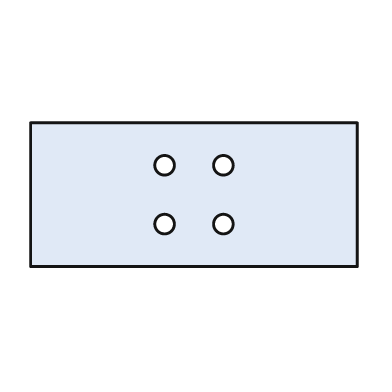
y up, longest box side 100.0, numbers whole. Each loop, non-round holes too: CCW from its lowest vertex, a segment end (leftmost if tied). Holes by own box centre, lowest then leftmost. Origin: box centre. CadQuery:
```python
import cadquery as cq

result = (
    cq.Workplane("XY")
    .moveTo(-50.0, -22.0)
    .lineTo(50.0, -22.0)
    .lineTo(50.0, 22.0)
    .lineTo(-50.0, 22.0)
    .close()
    .moveTo(-9.0, -9.0)
    .circle(3.0)
    .moveTo(9.0, -9.0)
    .circle(3.0)
    .moveTo(-9.0, 9.0)
    .circle(3.0)
    .moveTo(9.0, 9.0)
    .circle(3.0)
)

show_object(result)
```